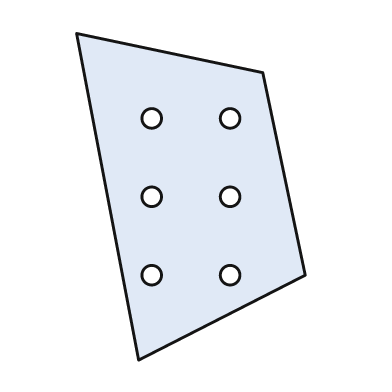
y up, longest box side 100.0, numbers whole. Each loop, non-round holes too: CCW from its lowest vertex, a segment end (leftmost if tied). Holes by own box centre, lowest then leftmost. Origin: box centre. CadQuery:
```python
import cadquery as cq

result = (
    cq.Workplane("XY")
    .moveTo(-16.0, -50.0)
    .lineTo(35.0, -24.0)
    .lineTo(22.0, 38.0)
    .lineTo(-35.0, 50.0)
    .close()
    .moveTo(-12.0, -24.0)
    .circle(3.0)
    .moveTo(12.0, -24.0)
    .circle(3.0)
    .moveTo(-12.0, 0.0)
    .circle(3.0)
    .moveTo(12.0, 0.0)
    .circle(3.0)
    .moveTo(-12.0, 24.0)
    .circle(3.0)
    .moveTo(12.0, 24.0)
    .circle(3.0)
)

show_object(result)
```